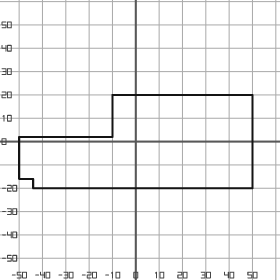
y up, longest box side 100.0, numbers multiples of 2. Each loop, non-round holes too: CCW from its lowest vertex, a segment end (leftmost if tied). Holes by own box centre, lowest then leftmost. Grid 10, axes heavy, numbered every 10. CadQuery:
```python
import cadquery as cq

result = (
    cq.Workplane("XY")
    .moveTo(-44.0, -20.0)
    .lineTo(50.0, -20.0)
    .lineTo(50.0, 20.0)
    .lineTo(-10.0, 20.0)
    .lineTo(-10.0, 2.0)
    .lineTo(-50.0, 2.0)
    .lineTo(-50.0, -16.0)
    .lineTo(-44.0, -16.0)
    .close()
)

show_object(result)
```